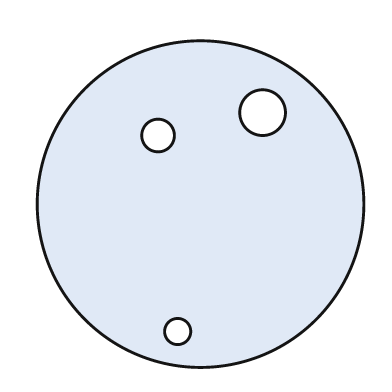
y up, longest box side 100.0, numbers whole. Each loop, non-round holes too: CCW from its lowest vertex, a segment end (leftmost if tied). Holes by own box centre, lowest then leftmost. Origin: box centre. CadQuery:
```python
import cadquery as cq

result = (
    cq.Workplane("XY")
    .moveTo(0.0, 0.0)
    .circle(50.0)
    .moveTo(-7.0, -39.0)
    .circle(4.0)
    .moveTo(-13.0, 21.0)
    .circle(5.0)
    .moveTo(19.0, 28.0)
    .circle(7.0)
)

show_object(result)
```